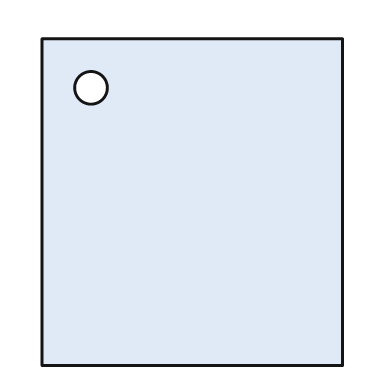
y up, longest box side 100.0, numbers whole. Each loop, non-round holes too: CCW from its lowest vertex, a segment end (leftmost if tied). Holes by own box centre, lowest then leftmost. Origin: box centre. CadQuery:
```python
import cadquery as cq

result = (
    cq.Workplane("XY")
    .moveTo(-46.0, -50.0)
    .lineTo(46.0, -50.0)
    .lineTo(46.0, 50.0)
    .lineTo(-46.0, 50.0)
    .close()
    .moveTo(-31.0, 35.0)
    .circle(5.0)
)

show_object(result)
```